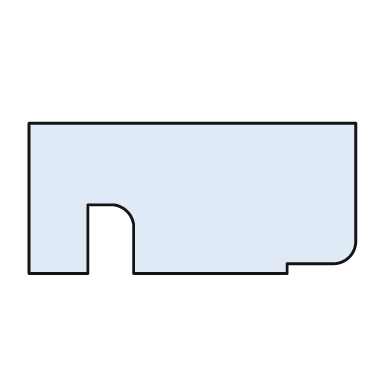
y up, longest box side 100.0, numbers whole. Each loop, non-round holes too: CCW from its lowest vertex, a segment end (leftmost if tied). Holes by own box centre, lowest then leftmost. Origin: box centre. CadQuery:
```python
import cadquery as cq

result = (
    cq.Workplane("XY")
    .moveTo(-50.0, -23.0)
    .lineTo(-32.0, -23.0)
    .lineTo(-32.0, -2.0)
    .lineTo(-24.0, -2.0)
    .threePointArc((-20.0, -4.0), (-18.0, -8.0))
    .lineTo(-18.0, -23.0)
    .lineTo(29.0, -23.0)
    .lineTo(29.0, -20.0)
    .lineTo(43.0, -20.0)
    .threePointArc((48.0, -18.0), (50.0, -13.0))
    .lineTo(50.0, 23.0)
    .lineTo(-50.0, 23.0)
    .close()
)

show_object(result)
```